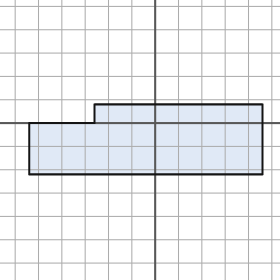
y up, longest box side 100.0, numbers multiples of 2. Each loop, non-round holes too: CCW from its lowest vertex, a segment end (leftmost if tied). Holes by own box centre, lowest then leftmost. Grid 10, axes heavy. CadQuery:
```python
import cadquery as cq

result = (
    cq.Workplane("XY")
    .moveTo(-54.0, -22.0)
    .lineTo(46.0, -22.0)
    .lineTo(46.0, 8.0)
    .lineTo(-26.0, 8.0)
    .lineTo(-26.0, 0.0)
    .lineTo(-54.0, 0.0)
    .close()
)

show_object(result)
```